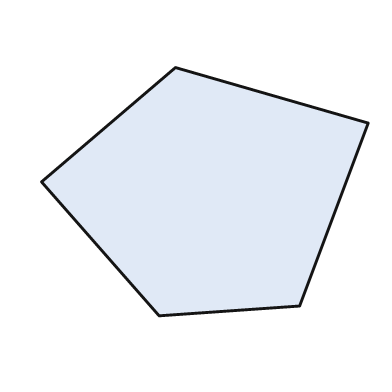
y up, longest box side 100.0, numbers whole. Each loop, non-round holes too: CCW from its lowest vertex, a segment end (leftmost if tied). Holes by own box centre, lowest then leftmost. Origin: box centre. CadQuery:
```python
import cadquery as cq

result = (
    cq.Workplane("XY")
    .moveTo(-14.0, -38.0)
    .lineTo(29.0, -35.0)
    .lineTo(50.0, 21.0)
    .lineTo(-9.0, 38.0)
    .lineTo(-50.0, 3.0)
    .close()
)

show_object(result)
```